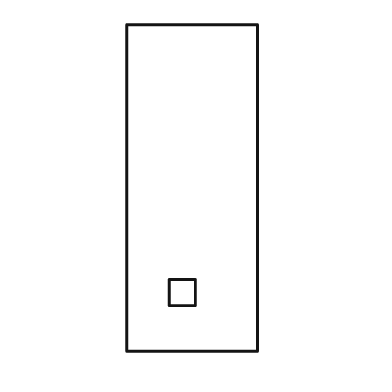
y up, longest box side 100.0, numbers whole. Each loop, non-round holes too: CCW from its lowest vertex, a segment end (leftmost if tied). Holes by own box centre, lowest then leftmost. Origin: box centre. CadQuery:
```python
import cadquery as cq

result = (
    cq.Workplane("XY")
    .moveTo(-20.0, -50.0)
    .lineTo(20.0, -50.0)
    .lineTo(20.0, 50.0)
    .lineTo(-20.0, 50.0)
    .close()
    .moveTo(-7.0, -36.0)
    .lineTo(1.0, -36.0)
    .lineTo(1.0, -28.0)
    .lineTo(-7.0, -28.0)
    .close()
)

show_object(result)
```